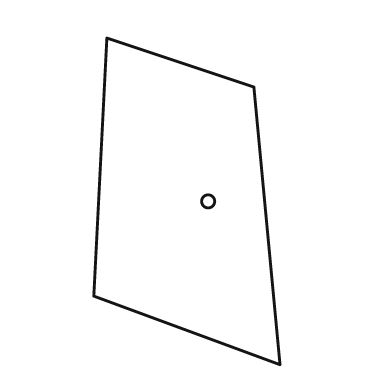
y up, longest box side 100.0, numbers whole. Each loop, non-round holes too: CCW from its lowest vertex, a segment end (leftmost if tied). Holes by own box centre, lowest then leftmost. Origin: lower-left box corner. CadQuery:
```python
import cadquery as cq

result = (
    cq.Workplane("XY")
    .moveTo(57.0, 0.0)
    .lineTo(49.0, 85.0)
    .lineTo(4.0, 100.0)
    .lineTo(0.0, 21.0)
    .close()
    .moveTo(35.0, 50.0)
    .circle(2.0)
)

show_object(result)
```